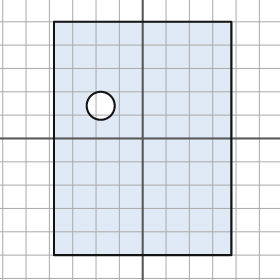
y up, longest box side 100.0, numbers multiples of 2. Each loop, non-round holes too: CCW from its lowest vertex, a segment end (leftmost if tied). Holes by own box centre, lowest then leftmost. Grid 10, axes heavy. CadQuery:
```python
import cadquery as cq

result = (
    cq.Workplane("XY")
    .moveTo(-38.0, -50.0)
    .lineTo(38.0, -50.0)
    .lineTo(38.0, 50.0)
    .lineTo(-38.0, 50.0)
    .close()
    .moveTo(-18.0, 14.0)
    .circle(6.0)
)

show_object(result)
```